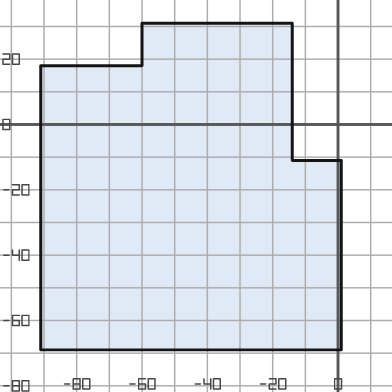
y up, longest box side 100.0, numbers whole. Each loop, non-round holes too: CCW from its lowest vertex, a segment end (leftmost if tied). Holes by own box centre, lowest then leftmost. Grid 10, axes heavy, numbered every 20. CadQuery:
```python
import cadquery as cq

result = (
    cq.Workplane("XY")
    .moveTo(-91.0, -69.0)
    .lineTo(1.0, -69.0)
    .lineTo(1.0, -11.0)
    .lineTo(-14.0, -11.0)
    .lineTo(-14.0, 31.0)
    .lineTo(-60.0, 31.0)
    .lineTo(-60.0, 18.0)
    .lineTo(-91.0, 18.0)
    .close()
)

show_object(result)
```